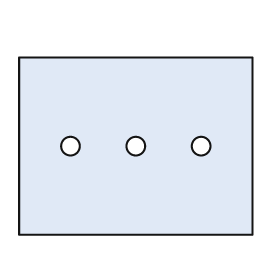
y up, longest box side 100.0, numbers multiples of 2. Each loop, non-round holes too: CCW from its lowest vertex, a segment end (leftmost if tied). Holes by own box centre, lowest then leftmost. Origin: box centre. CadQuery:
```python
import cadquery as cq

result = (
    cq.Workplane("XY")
    .moveTo(-50.0, -38.0)
    .lineTo(50.0, -38.0)
    .lineTo(50.0, 38.0)
    .lineTo(-50.0, 38.0)
    .close()
    .moveTo(-28.0, 0.0)
    .circle(4.0)
    .moveTo(0.0, 0.0)
    .circle(4.0)
    .moveTo(28.0, 0.0)
    .circle(4.0)
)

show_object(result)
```